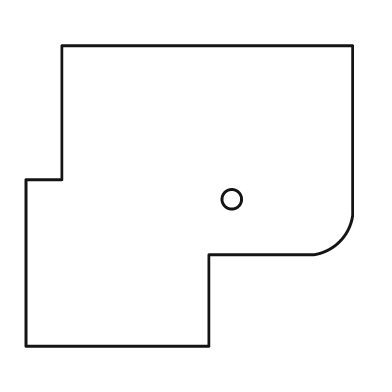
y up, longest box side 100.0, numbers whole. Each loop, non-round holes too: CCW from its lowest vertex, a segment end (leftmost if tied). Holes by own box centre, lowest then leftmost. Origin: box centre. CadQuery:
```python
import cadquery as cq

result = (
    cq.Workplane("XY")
    .moveTo(-50.0, -46.0)
    .lineTo(6.0, -46.0)
    .lineTo(6.0, -18.0)
    .lineTo(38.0, -18.0)
    .threePointArc((46.0, -14.0), (50.0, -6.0))
    .lineTo(50.0, 46.0)
    .lineTo(-39.0, 46.0)
    .lineTo(-39.0, 5.0)
    .lineTo(-50.0, 5.0)
    .close()
    .moveTo(13.0, -1.0)
    .circle(3.0)
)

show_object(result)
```